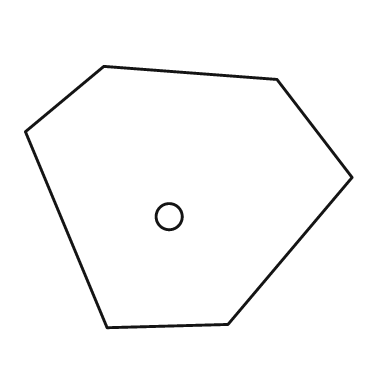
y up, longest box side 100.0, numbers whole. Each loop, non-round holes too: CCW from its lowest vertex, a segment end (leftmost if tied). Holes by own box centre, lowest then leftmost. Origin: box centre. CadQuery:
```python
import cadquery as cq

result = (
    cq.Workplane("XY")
    .moveTo(-25.0, -40.0)
    .lineTo(12.0, -39.0)
    .lineTo(50.0, 6.0)
    .lineTo(27.0, 36.0)
    .lineTo(-26.0, 40.0)
    .lineTo(-50.0, 20.0)
    .close()
    .moveTo(-6.0, -6.0)
    .circle(4.0)
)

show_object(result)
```